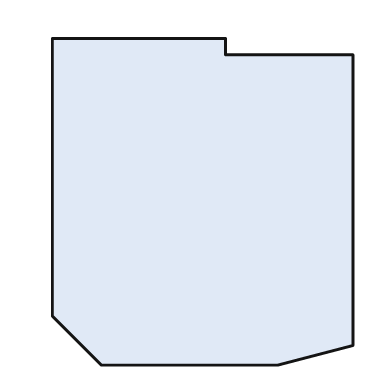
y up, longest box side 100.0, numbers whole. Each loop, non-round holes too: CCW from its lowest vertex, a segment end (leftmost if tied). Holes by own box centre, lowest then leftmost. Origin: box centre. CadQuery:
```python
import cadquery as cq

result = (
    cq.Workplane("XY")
    .moveTo(-31.0, -50.0)
    .lineTo(23.0, -50.0)
    .lineTo(46.0, -44.0)
    .lineTo(46.0, 45.0)
    .lineTo(7.0, 45.0)
    .lineTo(7.0, 50.0)
    .lineTo(-46.0, 50.0)
    .lineTo(-46.0, -35.0)
    .close()
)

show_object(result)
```